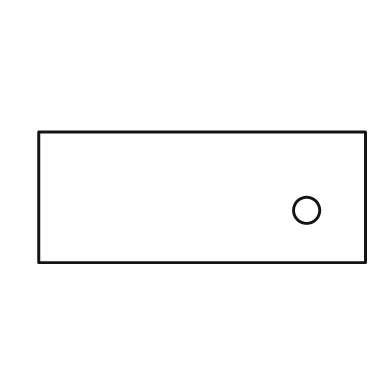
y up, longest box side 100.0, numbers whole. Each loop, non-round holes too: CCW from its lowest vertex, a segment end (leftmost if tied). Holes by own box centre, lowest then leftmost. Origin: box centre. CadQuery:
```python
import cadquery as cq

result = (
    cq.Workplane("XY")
    .moveTo(-50.0, -20.0)
    .lineTo(50.0, -20.0)
    .lineTo(50.0, 20.0)
    .lineTo(-50.0, 20.0)
    .close()
    .moveTo(32.0, -4.0)
    .circle(4.0)
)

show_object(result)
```